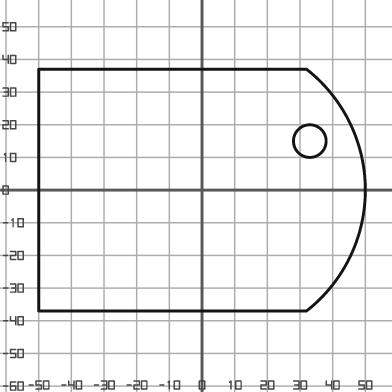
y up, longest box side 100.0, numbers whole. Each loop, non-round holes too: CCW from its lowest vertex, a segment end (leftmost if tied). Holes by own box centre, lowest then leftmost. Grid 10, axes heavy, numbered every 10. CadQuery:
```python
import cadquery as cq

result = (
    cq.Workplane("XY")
    .moveTo(-50.0, -37.0)
    .lineTo(32.0, -37.0)
    .threePointArc((50.0, 0.0), (32.0, 37.0))
    .lineTo(-50.0, 37.0)
    .close()
    .moveTo(33.0, 15.0)
    .circle(5.0)
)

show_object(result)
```